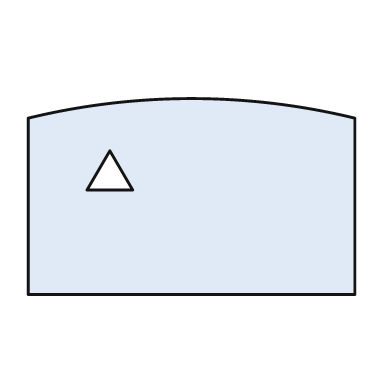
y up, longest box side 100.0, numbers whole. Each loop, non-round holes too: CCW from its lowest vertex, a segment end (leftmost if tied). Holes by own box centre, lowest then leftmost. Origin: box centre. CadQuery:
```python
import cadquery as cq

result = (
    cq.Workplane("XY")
    .moveTo(-50.0, -30.0)
    .lineTo(50.0, -30.0)
    .lineTo(50.0, 24.0)
    .threePointArc((0.0, 30.0), (-50.0, 24.0))
    .close()
    .moveTo(-32.0, 2.0)
    .lineTo(-18.0, 2.0)
    .lineTo(-25.0, 14.0)
    .close()
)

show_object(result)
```